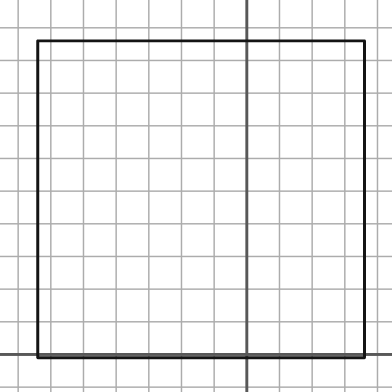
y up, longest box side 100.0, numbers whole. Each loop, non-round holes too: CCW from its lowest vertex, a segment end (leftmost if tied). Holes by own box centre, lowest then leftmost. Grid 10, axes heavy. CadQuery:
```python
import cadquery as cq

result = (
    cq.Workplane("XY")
    .moveTo(-64.0, -1.0)
    .lineTo(36.0, -1.0)
    .lineTo(36.0, 96.0)
    .lineTo(-64.0, 96.0)
    .close()
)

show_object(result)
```